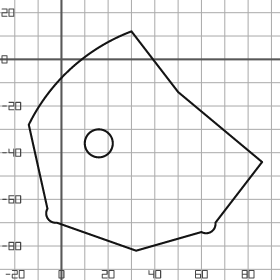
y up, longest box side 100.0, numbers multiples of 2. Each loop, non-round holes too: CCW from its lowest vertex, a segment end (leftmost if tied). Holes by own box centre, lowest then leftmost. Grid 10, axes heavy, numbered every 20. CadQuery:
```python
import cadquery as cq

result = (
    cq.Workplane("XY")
    .moveTo(32.0, -82.0)
    .lineTo(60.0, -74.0)
    .threePointArc((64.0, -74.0), (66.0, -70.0))
    .lineTo(86.0, -44.0)
    .lineTo(50.0, -14.0)
    .lineTo(30.0, 12.0)
    .threePointArc((4.0, -4.0), (-14.0, -28.0))
    .lineTo(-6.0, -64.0)
    .threePointArc((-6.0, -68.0), (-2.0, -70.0))
    .close()
    .moveTo(16.0, -36.0)
    .circle(6.0)
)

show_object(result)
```